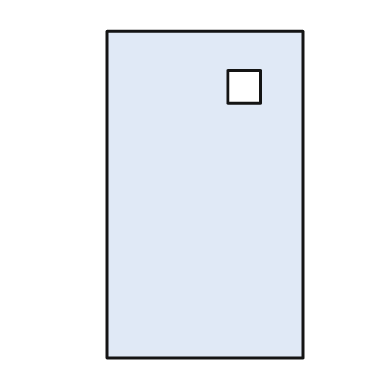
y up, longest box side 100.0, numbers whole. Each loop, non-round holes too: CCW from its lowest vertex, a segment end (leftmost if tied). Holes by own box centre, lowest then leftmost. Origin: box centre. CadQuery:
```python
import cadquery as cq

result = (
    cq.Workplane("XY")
    .moveTo(-30.0, -50.0)
    .lineTo(30.0, -50.0)
    .lineTo(30.0, 50.0)
    .lineTo(-30.0, 50.0)
    .close()
    .moveTo(7.0, 28.0)
    .lineTo(17.0, 28.0)
    .lineTo(17.0, 38.0)
    .lineTo(7.0, 38.0)
    .close()
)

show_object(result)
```